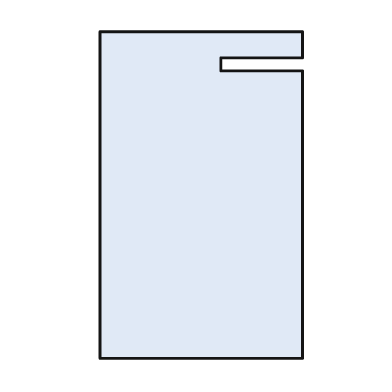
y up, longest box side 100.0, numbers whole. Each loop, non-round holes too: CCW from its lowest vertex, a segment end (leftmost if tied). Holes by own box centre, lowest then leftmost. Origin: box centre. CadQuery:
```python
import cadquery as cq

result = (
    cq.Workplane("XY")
    .moveTo(-31.0, -50.0)
    .lineTo(31.0, -50.0)
    .lineTo(31.0, 38.0)
    .lineTo(6.0, 38.0)
    .lineTo(6.0, 42.0)
    .lineTo(31.0, 42.0)
    .lineTo(31.0, 50.0)
    .lineTo(-31.0, 50.0)
    .close()
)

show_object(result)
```